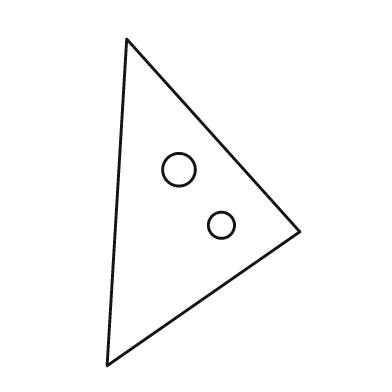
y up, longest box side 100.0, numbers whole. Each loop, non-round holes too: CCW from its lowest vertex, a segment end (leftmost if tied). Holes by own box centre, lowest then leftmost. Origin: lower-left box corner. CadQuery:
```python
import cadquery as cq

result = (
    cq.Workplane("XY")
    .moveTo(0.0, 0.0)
    .lineTo(59.0, 41.0)
    .lineTo(6.0, 100.0)
    .close()
    .moveTo(35.0, 43.0)
    .circle(4.0)
    .moveTo(22.0, 60.0)
    .circle(5.0)
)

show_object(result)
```